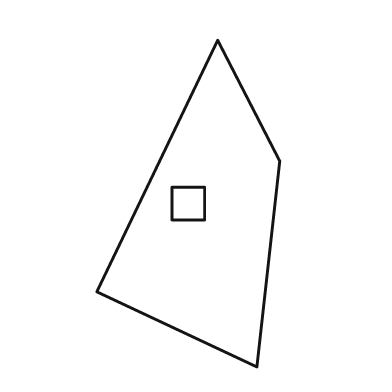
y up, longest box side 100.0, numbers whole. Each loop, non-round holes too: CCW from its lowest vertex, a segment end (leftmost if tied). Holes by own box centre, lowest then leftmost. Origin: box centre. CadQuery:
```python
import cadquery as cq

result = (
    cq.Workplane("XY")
    .moveTo(21.0, -50.0)
    .lineTo(28.0, 13.0)
    .lineTo(9.0, 50.0)
    .lineTo(-28.0, -27.0)
    .close()
    .moveTo(-5.0, -5.0)
    .lineTo(5.0, -5.0)
    .lineTo(5.0, 5.0)
    .lineTo(-5.0, 5.0)
    .close()
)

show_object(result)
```